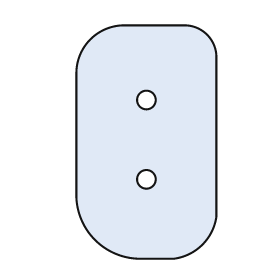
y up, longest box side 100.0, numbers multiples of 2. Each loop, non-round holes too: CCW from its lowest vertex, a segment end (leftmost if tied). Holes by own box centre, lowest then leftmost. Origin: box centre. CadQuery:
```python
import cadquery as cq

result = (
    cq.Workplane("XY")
    .moveTo(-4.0, -50.0)
    .lineTo(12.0, -50.0)
    .threePointArc((24.0, -44.0), (30.0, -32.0))
    .lineTo(30.0, 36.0)
    .threePointArc((26.0, 46.0), (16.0, 50.0))
    .lineTo(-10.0, 50.0)
    .threePointArc((-24.0, 44.0), (-30.0, 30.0))
    .lineTo(-30.0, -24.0)
    .threePointArc((-22.0, -42.0), (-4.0, -50.0))
    .close()
    .moveTo(0.0, -16.0)
    .circle(4.0)
    .moveTo(0.0, 18.0)
    .circle(4.0)
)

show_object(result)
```